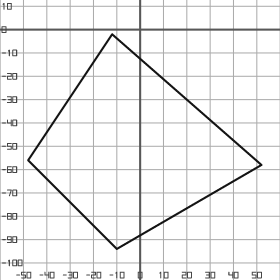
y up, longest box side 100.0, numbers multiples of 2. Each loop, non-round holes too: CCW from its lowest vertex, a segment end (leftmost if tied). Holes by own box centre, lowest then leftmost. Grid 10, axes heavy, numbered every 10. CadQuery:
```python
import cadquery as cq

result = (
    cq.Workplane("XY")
    .moveTo(-10.0, -94.0)
    .lineTo(52.0, -58.0)
    .lineTo(-12.0, -2.0)
    .lineTo(-48.0, -56.0)
    .close()
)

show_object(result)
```